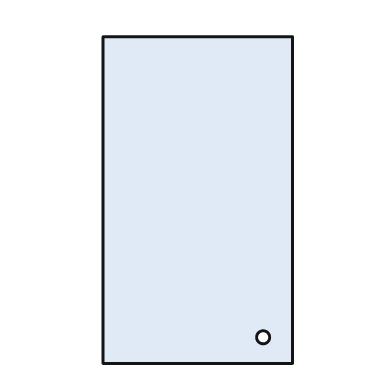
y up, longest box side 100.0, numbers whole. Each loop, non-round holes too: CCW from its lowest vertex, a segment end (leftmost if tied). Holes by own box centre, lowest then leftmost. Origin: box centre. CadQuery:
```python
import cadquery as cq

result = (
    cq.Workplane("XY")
    .moveTo(-29.0, -50.0)
    .lineTo(29.0, -50.0)
    .lineTo(29.0, 50.0)
    .lineTo(-29.0, 50.0)
    .close()
    .moveTo(20.0, -42.0)
    .circle(2.0)
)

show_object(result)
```